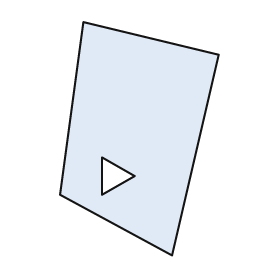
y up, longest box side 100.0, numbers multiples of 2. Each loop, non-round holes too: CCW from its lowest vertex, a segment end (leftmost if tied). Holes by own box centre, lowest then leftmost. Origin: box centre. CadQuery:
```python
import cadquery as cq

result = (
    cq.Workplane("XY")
    .moveTo(14.0, -50.0)
    .lineTo(34.0, 36.0)
    .lineTo(-24.0, 50.0)
    .lineTo(-34.0, -24.0)
    .close()
    .moveTo(-16.0, -24.0)
    .lineTo(-2.0, -16.0)
    .lineTo(-16.0, -8.0)
    .close()
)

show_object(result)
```